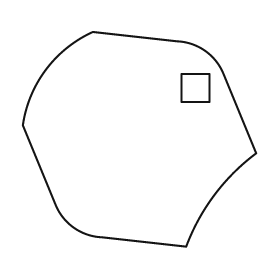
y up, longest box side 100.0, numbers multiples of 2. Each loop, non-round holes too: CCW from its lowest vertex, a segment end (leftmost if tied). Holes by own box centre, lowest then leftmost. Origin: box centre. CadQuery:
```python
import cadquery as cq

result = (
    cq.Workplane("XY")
    .moveTo(20.0, -46.0)
    .threePointArc((32.0, -24.0), (50.0, -6.0))
    .lineTo(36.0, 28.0)
    .threePointArc((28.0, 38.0), (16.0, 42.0))
    .lineTo(-20.0, 46.0)
    .threePointArc((-40.0, 30.0), (-50.0, 6.0))
    .lineTo(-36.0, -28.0)
    .threePointArc((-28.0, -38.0), (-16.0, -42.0))
    .close()
    .moveTo(18.0, 16.0)
    .lineTo(30.0, 16.0)
    .lineTo(30.0, 28.0)
    .lineTo(18.0, 28.0)
    .close()
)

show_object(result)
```